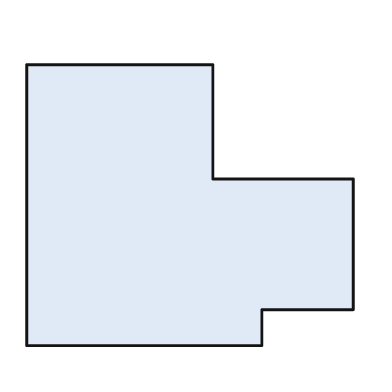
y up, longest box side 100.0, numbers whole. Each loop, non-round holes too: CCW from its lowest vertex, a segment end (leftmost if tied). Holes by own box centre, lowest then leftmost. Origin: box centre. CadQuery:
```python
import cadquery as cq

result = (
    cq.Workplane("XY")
    .moveTo(-50.0, -43.0)
    .lineTo(22.0, -43.0)
    .lineTo(22.0, -32.0)
    .lineTo(50.0, -32.0)
    .lineTo(50.0, 8.0)
    .lineTo(7.0, 8.0)
    .lineTo(7.0, 43.0)
    .lineTo(-50.0, 43.0)
    .close()
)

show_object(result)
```